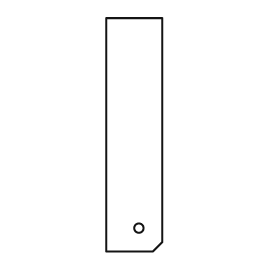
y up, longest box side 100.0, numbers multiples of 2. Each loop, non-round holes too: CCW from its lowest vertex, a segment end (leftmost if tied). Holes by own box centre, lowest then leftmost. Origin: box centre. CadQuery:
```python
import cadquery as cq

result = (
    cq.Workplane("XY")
    .moveTo(-12.0, -50.0)
    .lineTo(8.0, -50.0)
    .lineTo(12.0, -46.0)
    .lineTo(12.0, 50.0)
    .lineTo(-12.0, 50.0)
    .close()
    .moveTo(2.0, -40.0)
    .circle(2.0)
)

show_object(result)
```